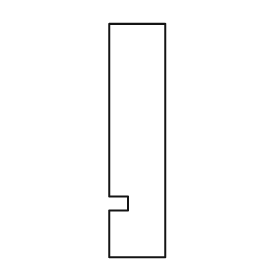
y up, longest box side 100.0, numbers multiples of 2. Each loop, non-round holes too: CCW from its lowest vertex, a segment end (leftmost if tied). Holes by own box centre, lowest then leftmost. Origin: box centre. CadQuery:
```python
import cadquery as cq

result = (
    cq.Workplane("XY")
    .moveTo(-12.0, -50.0)
    .lineTo(12.0, -50.0)
    .lineTo(12.0, 50.0)
    .lineTo(-12.0, 50.0)
    .lineTo(-12.0, -24.0)
    .lineTo(-4.0, -24.0)
    .lineTo(-4.0, -30.0)
    .lineTo(-12.0, -30.0)
    .close()
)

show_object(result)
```